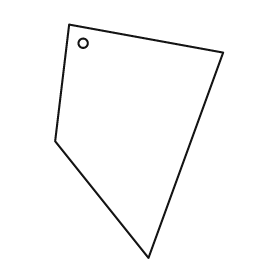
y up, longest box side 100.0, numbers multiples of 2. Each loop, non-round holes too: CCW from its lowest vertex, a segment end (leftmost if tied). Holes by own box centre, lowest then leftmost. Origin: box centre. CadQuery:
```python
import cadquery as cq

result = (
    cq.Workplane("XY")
    .moveTo(4.0, -50.0)
    .lineTo(36.0, 38.0)
    .lineTo(-30.0, 50.0)
    .lineTo(-36.0, 0.0)
    .close()
    .moveTo(-24.0, 42.0)
    .circle(2.0)
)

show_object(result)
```